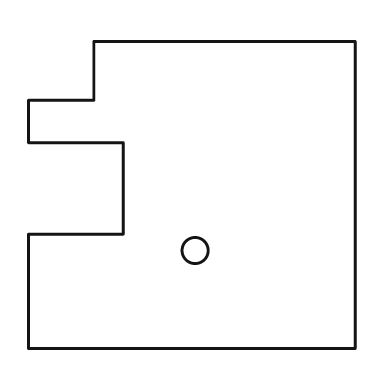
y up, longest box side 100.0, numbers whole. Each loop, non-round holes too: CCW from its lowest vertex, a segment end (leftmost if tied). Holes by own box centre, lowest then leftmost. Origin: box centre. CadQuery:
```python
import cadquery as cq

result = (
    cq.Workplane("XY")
    .moveTo(-50.0, -47.0)
    .lineTo(50.0, -47.0)
    .lineTo(50.0, 47.0)
    .lineTo(-30.0, 47.0)
    .lineTo(-30.0, 29.0)
    .lineTo(-50.0, 29.0)
    .lineTo(-50.0, 16.0)
    .lineTo(-21.0, 16.0)
    .lineTo(-21.0, -12.0)
    .lineTo(-50.0, -12.0)
    .close()
    .moveTo(1.0, -17.0)
    .circle(4.0)
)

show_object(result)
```